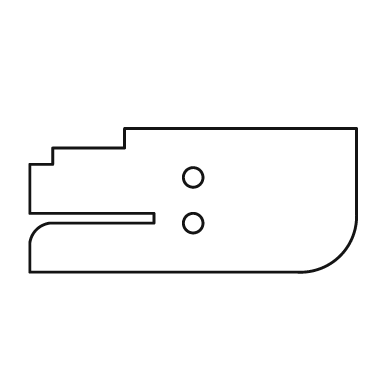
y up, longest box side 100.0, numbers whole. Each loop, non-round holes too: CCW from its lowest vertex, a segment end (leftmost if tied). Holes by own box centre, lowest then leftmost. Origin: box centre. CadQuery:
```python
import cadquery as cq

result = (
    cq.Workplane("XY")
    .moveTo(-50.0, -22.0)
    .lineTo(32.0, -22.0)
    .threePointArc((45.0, -17.0), (50.0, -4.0))
    .lineTo(50.0, 22.0)
    .lineTo(-21.0, 22.0)
    .lineTo(-21.0, 16.0)
    .lineTo(-43.0, 16.0)
    .lineTo(-43.0, 11.0)
    .lineTo(-50.0, 11.0)
    .lineTo(-50.0, -4.0)
    .lineTo(-12.0, -4.0)
    .lineTo(-12.0, -7.0)
    .lineTo(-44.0, -7.0)
    .threePointArc((-48.0, -9.0), (-50.0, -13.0))
    .close()
    .moveTo(0.0, -7.0)
    .circle(3.0)
    .moveTo(0.0, 7.0)
    .circle(3.0)
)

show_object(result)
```